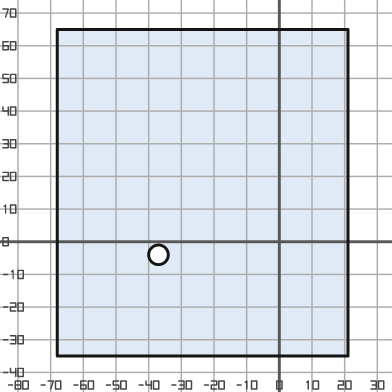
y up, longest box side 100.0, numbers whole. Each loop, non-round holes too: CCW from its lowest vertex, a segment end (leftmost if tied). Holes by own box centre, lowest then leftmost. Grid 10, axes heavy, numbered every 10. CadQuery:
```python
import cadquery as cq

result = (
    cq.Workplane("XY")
    .moveTo(-68.0, -35.0)
    .lineTo(21.0, -35.0)
    .lineTo(21.0, 65.0)
    .lineTo(-68.0, 65.0)
    .close()
    .moveTo(-37.0, -4.0)
    .circle(3.0)
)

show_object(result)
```